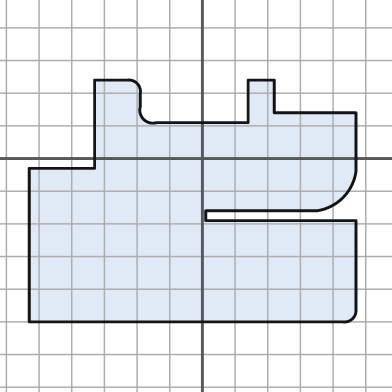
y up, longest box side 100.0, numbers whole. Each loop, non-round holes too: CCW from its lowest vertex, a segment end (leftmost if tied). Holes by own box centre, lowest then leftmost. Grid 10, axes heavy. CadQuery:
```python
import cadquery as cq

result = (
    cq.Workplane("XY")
    .moveTo(-53.0, -50.0)
    .lineTo(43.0, -50.0)
    .threePointArc((46.0, -49.0), (47.0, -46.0))
    .lineTo(47.0, -19.0)
    .lineTo(1.0, -19.0)
    .lineTo(1.0, -16.0)
    .lineTo(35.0, -16.0)
    .threePointArc((43.0, -12.0), (47.0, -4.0))
    .lineTo(47.0, 14.0)
    .lineTo(22.0, 14.0)
    .lineTo(22.0, 24.0)
    .lineTo(14.0, 24.0)
    .lineTo(14.0, 11.0)
    .lineTo(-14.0, 11.0)
    .threePointArc((-18.0, 12.0), (-19.0, 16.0))
    .lineTo(-19.0, 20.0)
    .threePointArc((-20.0, 23.0), (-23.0, 24.0))
    .lineTo(-33.0, 24.0)
    .lineTo(-33.0, -3.0)
    .lineTo(-53.0, -3.0)
    .close()
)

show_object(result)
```